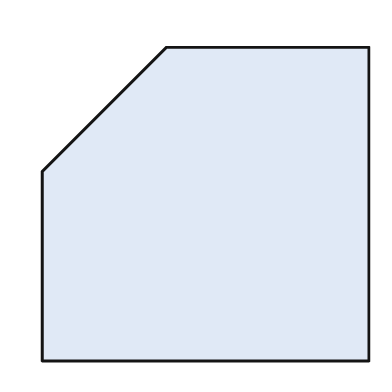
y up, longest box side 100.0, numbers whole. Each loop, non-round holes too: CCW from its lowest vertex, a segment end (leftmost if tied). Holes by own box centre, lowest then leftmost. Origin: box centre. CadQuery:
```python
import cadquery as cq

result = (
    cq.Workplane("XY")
    .moveTo(-50.0, -48.0)
    .lineTo(50.0, -48.0)
    .lineTo(50.0, 48.0)
    .lineTo(-12.0, 48.0)
    .lineTo(-50.0, 10.0)
    .close()
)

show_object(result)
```